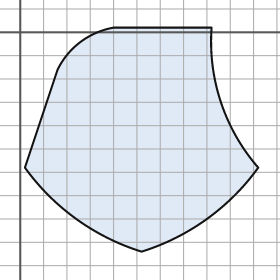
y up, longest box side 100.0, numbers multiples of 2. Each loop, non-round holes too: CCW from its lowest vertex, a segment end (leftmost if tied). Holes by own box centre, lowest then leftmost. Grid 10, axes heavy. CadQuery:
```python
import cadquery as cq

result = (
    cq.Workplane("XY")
    .moveTo(52.0, -94.0)
    .threePointArc((80.0, -80.0), (102.0, -58.0))
    .threePointArc((86.0, -30.0), (82.0, 2.0))
    .lineTo(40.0, 2.0)
    .threePointArc((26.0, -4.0), (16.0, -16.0))
    .lineTo(2.0, -58.0)
    .threePointArc((24.0, -80.0), (52.0, -94.0))
    .close()
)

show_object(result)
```